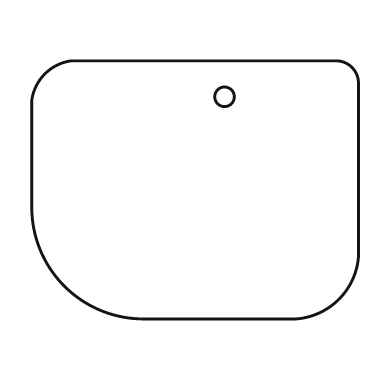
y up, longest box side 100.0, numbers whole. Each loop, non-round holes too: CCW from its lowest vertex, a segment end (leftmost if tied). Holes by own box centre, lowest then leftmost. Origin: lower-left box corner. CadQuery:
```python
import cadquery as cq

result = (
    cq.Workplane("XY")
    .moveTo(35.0, 0.0)
    .lineTo(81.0, 0.0)
    .threePointArc((94.0, 6.0), (100.0, 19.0))
    .lineTo(100.0, 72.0)
    .threePointArc((98.0, 77.0), (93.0, 79.0))
    .lineTo(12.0, 79.0)
    .threePointArc((4.0, 75.0), (0.0, 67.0))
    .lineTo(0.0, 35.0)
    .threePointArc((10.0, 10.0), (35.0, 0.0))
    .close()
    .moveTo(59.0, 68.0)
    .circle(3.0)
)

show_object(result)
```